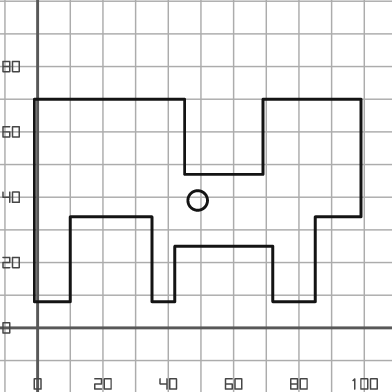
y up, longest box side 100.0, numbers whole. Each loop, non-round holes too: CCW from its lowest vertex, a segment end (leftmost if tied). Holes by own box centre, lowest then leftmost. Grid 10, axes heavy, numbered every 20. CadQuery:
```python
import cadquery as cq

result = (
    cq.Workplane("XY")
    .moveTo(-1.0, 8.0)
    .lineTo(10.0, 8.0)
    .lineTo(10.0, 34.0)
    .lineTo(35.0, 34.0)
    .lineTo(35.0, 8.0)
    .lineTo(42.0, 8.0)
    .lineTo(42.0, 25.0)
    .lineTo(72.0, 25.0)
    .lineTo(72.0, 8.0)
    .lineTo(85.0, 8.0)
    .lineTo(85.0, 34.0)
    .lineTo(99.0, 34.0)
    .lineTo(99.0, 70.0)
    .lineTo(69.0, 70.0)
    .lineTo(69.0, 47.0)
    .lineTo(45.0, 47.0)
    .lineTo(45.0, 70.0)
    .lineTo(-1.0, 70.0)
    .close()
    .moveTo(49.0, 39.0)
    .circle(3.0)
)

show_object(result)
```